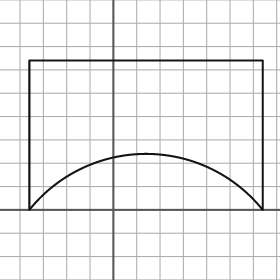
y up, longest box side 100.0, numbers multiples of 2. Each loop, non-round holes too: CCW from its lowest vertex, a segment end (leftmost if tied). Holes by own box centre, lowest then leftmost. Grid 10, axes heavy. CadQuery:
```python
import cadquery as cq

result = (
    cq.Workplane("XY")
    .moveTo(-36.0, 0.0)
    .threePointArc((14.0, 24.0), (64.0, 0.0))
    .lineTo(64.0, 64.0)
    .lineTo(-36.0, 64.0)
    .close()
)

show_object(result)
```